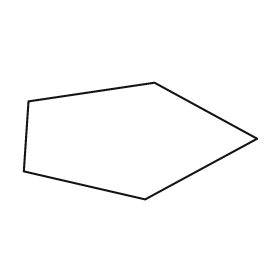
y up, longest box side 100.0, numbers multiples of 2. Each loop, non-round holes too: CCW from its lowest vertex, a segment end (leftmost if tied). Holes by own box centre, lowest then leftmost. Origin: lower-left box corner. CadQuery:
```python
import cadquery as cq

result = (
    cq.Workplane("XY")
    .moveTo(52.0, 0.0)
    .lineTo(100.0, 26.0)
    .lineTo(56.0, 50.0)
    .lineTo(2.0, 42.0)
    .lineTo(0.0, 12.0)
    .close()
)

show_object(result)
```